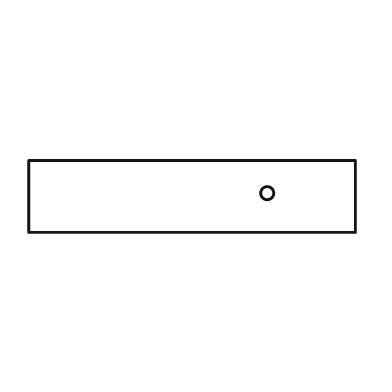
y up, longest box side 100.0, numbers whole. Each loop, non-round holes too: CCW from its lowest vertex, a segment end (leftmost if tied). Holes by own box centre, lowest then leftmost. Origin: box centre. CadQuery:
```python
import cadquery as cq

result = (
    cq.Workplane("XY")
    .moveTo(-50.0, -11.0)
    .lineTo(50.0, -11.0)
    .lineTo(50.0, 11.0)
    .lineTo(-50.0, 11.0)
    .close()
    .moveTo(23.0, 1.0)
    .circle(2.0)
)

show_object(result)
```